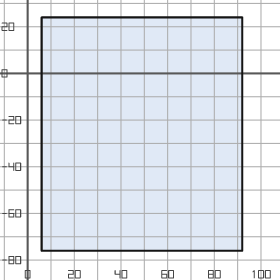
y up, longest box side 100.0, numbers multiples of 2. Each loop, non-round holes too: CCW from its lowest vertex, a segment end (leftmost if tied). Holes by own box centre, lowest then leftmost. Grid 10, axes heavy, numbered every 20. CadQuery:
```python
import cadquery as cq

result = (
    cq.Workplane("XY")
    .moveTo(6.0, -76.0)
    .lineTo(92.0, -76.0)
    .lineTo(92.0, 24.0)
    .lineTo(6.0, 24.0)
    .close()
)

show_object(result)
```